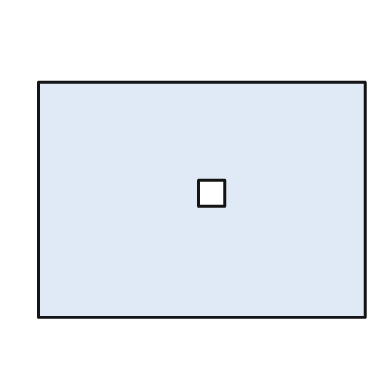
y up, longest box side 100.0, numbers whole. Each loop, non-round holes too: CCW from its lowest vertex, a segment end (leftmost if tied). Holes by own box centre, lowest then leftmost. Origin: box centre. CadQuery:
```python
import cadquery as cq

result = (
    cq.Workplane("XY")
    .moveTo(-50.0, -36.0)
    .lineTo(50.0, -36.0)
    .lineTo(50.0, 36.0)
    .lineTo(-50.0, 36.0)
    .close()
    .moveTo(-1.0, -2.0)
    .lineTo(7.0, -2.0)
    .lineTo(7.0, 6.0)
    .lineTo(-1.0, 6.0)
    .close()
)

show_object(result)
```